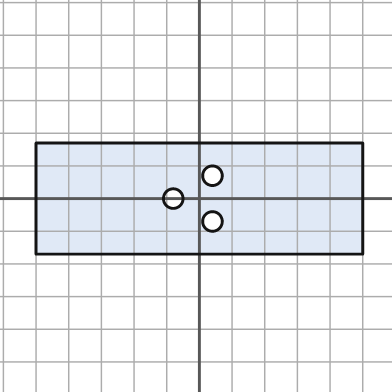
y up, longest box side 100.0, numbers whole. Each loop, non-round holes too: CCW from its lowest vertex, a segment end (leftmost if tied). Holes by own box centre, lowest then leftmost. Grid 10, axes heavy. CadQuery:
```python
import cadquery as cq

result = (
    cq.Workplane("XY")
    .moveTo(-50.0, -17.0)
    .lineTo(50.0, -17.0)
    .lineTo(50.0, 17.0)
    .lineTo(-50.0, 17.0)
    .close()
    .moveTo(4.0, -7.0)
    .circle(3.0)
    .moveTo(-8.0, 0.0)
    .circle(3.0)
    .moveTo(4.0, 7.0)
    .circle(3.0)
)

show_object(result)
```